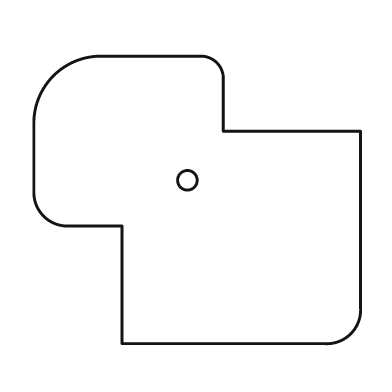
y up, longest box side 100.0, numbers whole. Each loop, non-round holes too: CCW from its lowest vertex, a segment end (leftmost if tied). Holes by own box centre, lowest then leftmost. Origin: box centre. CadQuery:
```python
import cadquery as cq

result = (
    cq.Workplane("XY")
    .moveTo(-23.0, -44.0)
    .lineTo(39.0, -44.0)
    .threePointArc((47.0, -41.0), (50.0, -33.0))
    .lineTo(50.0, 21.0)
    .lineTo(8.0, 21.0)
    .lineTo(8.0, 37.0)
    .threePointArc((6.0, 42.0), (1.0, 44.0))
    .lineTo(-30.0, 44.0)
    .threePointArc((-44.0, 38.0), (-50.0, 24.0))
    .lineTo(-50.0, 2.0)
    .threePointArc((-47.0, -5.0), (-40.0, -8.0))
    .lineTo(-23.0, -8.0)
    .close()
    .moveTo(-3.0, 6.0)
    .circle(3.0)
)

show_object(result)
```